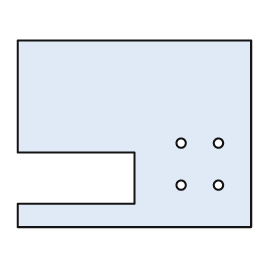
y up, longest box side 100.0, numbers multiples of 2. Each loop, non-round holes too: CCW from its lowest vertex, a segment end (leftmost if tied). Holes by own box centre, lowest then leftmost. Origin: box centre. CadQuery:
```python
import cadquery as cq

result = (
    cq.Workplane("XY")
    .moveTo(-50.0, -40.0)
    .lineTo(50.0, -40.0)
    .lineTo(50.0, 40.0)
    .lineTo(-50.0, 40.0)
    .lineTo(-50.0, -8.0)
    .lineTo(0.0, -8.0)
    .lineTo(0.0, -30.0)
    .lineTo(-50.0, -30.0)
    .close()
    .moveTo(20.0, -22.0)
    .circle(2.0)
    .moveTo(36.0, -22.0)
    .circle(2.0)
    .moveTo(20.0, -4.0)
    .circle(2.0)
    .moveTo(36.0, -4.0)
    .circle(2.0)
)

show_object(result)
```